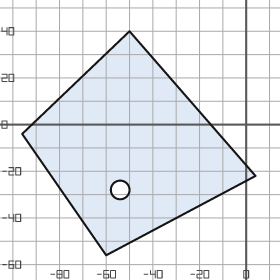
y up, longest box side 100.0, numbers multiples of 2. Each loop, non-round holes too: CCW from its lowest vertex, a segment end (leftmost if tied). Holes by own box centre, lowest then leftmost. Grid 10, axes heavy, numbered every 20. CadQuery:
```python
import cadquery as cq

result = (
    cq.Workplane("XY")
    .moveTo(-60.0, -56.0)
    .lineTo(4.0, -22.0)
    .lineTo(-50.0, 40.0)
    .lineTo(-96.0, -4.0)
    .close()
    .moveTo(-54.0, -28.0)
    .circle(4.0)
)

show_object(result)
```